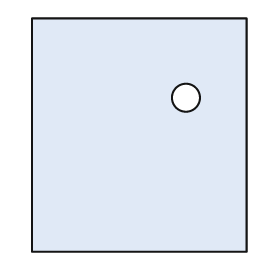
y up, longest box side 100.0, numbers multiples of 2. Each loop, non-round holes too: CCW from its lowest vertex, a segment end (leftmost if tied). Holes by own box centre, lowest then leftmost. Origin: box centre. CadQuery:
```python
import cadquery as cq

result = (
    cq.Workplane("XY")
    .moveTo(-46.0, -50.0)
    .lineTo(46.0, -50.0)
    .lineTo(46.0, 50.0)
    .lineTo(-46.0, 50.0)
    .close()
    .moveTo(20.0, 16.0)
    .circle(6.0)
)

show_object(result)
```